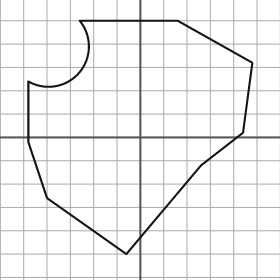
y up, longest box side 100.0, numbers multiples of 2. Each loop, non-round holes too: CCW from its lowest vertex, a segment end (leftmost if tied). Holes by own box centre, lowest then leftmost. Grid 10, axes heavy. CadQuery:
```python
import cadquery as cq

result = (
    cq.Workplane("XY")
    .moveTo(-6.0, -50.0)
    .lineTo(26.0, -12.0)
    .lineTo(44.0, 2.0)
    .lineTo(48.0, 32.0)
    .lineTo(16.0, 50.0)
    .lineTo(-26.0, 50.0)
    .threePointArc((-26.0, 28.0), (-48.0, 24.0))
    .lineTo(-48.0, -2.0)
    .lineTo(-40.0, -26.0)
    .close()
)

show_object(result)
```